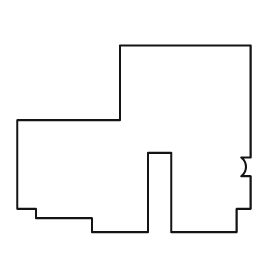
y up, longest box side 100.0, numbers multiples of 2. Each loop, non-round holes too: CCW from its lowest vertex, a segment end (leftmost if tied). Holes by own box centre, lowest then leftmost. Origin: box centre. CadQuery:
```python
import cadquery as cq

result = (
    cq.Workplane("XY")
    .moveTo(-18.0, -40.0)
    .lineTo(6.0, -40.0)
    .lineTo(6.0, -6.0)
    .lineTo(16.0, -6.0)
    .lineTo(16.0, -40.0)
    .lineTo(44.0, -40.0)
    .lineTo(44.0, -30.0)
    .lineTo(50.0, -30.0)
    .lineTo(50.0, -16.0)
    .lineTo(46.0, -16.0)
    .threePointArc((48.0, -12.0), (46.0, -8.0))
    .lineTo(50.0, -8.0)
    .lineTo(50.0, 40.0)
    .lineTo(-6.0, 40.0)
    .lineTo(-6.0, 8.0)
    .lineTo(-50.0, 8.0)
    .lineTo(-50.0, -30.0)
    .lineTo(-42.0, -30.0)
    .lineTo(-42.0, -34.0)
    .lineTo(-18.0, -34.0)
    .close()
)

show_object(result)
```